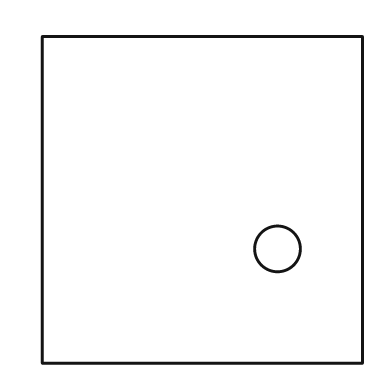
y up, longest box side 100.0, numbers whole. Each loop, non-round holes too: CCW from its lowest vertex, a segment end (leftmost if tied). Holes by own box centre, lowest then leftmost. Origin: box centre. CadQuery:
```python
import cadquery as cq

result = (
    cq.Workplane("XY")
    .moveTo(-49.0, -50.0)
    .lineTo(49.0, -50.0)
    .lineTo(49.0, 50.0)
    .lineTo(-49.0, 50.0)
    .close()
    .moveTo(23.0, -15.0)
    .circle(7.0)
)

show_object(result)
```